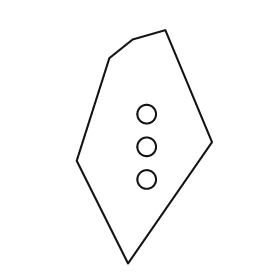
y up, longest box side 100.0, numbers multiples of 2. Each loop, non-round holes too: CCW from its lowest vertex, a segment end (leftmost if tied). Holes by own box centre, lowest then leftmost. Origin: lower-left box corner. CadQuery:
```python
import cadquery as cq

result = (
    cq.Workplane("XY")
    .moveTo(22.0, 0.0)
    .lineTo(58.0, 52.0)
    .lineTo(38.0, 100.0)
    .lineTo(24.0, 96.0)
    .lineTo(14.0, 88.0)
    .lineTo(0.0, 44.0)
    .close()
    .moveTo(30.0, 36.0)
    .circle(4.0)
    .moveTo(30.0, 50.0)
    .circle(4.0)
    .moveTo(30.0, 64.0)
    .circle(4.0)
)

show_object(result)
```